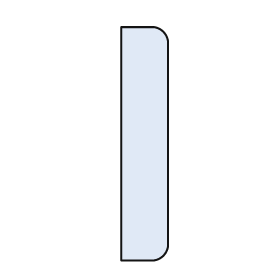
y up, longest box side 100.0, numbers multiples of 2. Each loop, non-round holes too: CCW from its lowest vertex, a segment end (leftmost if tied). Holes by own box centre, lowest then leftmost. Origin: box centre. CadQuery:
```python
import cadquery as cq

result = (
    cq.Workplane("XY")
    .moveTo(-10.0, -50.0)
    .lineTo(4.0, -50.0)
    .threePointArc((8.0, -48.0), (10.0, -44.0))
    .lineTo(10.0, 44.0)
    .threePointArc((8.0, 48.0), (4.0, 50.0))
    .lineTo(-10.0, 50.0)
    .close()
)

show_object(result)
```